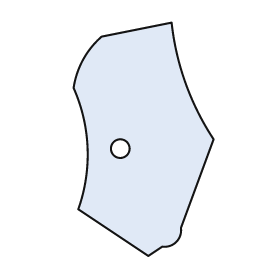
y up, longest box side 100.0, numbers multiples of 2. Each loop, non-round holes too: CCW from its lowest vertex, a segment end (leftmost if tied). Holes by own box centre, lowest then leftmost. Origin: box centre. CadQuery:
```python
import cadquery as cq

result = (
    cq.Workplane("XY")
    .moveTo(2.0, -50.0)
    .lineTo(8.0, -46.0)
    .threePointArc((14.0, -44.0), (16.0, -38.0))
    .lineTo(30.0, 0.0)
    .threePointArc((18.0, 24.0), (12.0, 50.0))
    .lineTo(-18.0, 44.0)
    .threePointArc((-26.0, 34.0), (-30.0, 22.0))
    .threePointArc((-24.0, -4.0), (-28.0, -30.0))
    .close()
    .moveTo(-10.0, -4.0)
    .circle(4.0)
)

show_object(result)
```